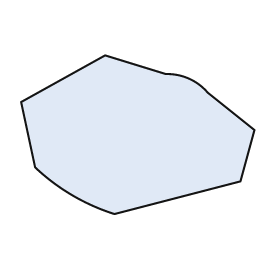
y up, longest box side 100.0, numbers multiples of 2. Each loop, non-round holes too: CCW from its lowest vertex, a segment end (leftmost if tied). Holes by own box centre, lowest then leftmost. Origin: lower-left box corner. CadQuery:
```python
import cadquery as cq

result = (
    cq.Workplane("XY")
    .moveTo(40.0, 0.0)
    .lineTo(94.0, 14.0)
    .lineTo(100.0, 36.0)
    .lineTo(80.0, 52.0)
    .threePointArc((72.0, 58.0), (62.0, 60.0))
    .lineTo(36.0, 68.0)
    .lineTo(0.0, 48.0)
    .lineTo(6.0, 20.0)
    .threePointArc((22.0, 8.0), (40.0, 0.0))
    .close()
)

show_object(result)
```